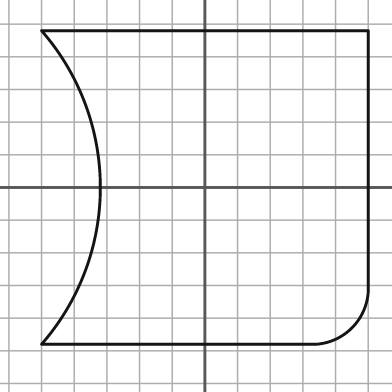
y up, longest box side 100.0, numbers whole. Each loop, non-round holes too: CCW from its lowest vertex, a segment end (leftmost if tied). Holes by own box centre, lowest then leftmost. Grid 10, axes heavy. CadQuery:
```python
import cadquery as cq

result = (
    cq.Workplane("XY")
    .moveTo(-50.0, -48.0)
    .lineTo(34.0, -48.0)
    .threePointArc((45.0, -43.0), (50.0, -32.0))
    .lineTo(50.0, 48.0)
    .lineTo(-50.0, 48.0)
    .threePointArc((-32.0, 0.0), (-50.0, -48.0))
    .close()
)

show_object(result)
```